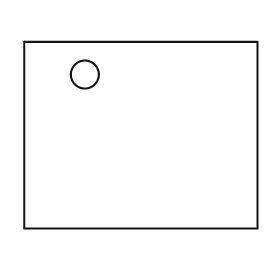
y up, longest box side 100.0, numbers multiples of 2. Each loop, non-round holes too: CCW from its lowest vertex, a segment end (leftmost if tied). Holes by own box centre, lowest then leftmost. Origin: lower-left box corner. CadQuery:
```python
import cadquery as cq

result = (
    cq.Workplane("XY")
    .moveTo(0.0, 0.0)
    .lineTo(100.0, 0.0)
    .lineTo(100.0, 80.0)
    .lineTo(0.0, 80.0)
    .close()
    .moveTo(26.0, 66.0)
    .circle(6.0)
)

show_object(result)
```